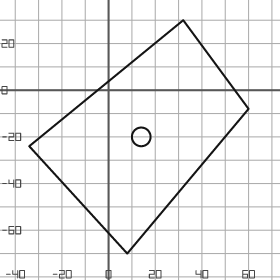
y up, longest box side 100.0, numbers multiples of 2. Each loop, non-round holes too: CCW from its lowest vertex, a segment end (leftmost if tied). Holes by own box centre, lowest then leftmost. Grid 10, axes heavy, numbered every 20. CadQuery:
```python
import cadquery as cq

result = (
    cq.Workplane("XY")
    .moveTo(8.0, -70.0)
    .lineTo(60.0, -8.0)
    .lineTo(32.0, 30.0)
    .lineTo(-34.0, -24.0)
    .close()
    .moveTo(14.0, -20.0)
    .circle(4.0)
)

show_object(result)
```